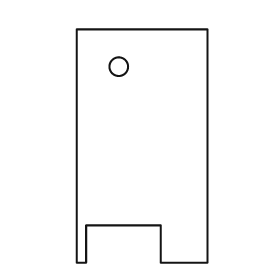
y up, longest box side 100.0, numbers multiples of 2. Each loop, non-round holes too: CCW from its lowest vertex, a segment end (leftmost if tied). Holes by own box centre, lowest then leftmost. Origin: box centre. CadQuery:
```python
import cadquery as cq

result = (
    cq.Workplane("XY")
    .moveTo(-28.0, -50.0)
    .lineTo(-24.0, -50.0)
    .lineTo(-24.0, -34.0)
    .lineTo(8.0, -34.0)
    .lineTo(8.0, -50.0)
    .lineTo(28.0, -50.0)
    .lineTo(28.0, 50.0)
    .lineTo(-28.0, 50.0)
    .close()
    .moveTo(-10.0, 34.0)
    .circle(4.0)
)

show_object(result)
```